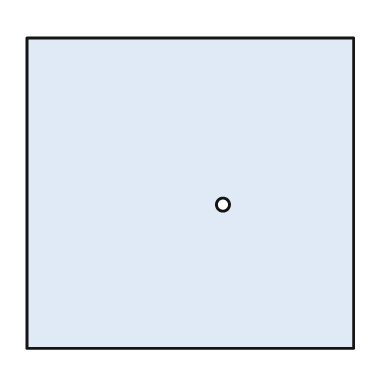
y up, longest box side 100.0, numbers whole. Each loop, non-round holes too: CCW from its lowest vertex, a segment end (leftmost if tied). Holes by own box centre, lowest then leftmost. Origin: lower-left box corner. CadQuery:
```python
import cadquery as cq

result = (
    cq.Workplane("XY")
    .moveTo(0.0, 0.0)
    .lineTo(100.0, 0.0)
    .lineTo(100.0, 95.0)
    .lineTo(0.0, 95.0)
    .close()
    .moveTo(60.0, 44.0)
    .circle(2.0)
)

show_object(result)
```